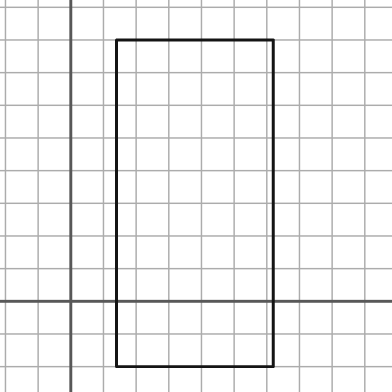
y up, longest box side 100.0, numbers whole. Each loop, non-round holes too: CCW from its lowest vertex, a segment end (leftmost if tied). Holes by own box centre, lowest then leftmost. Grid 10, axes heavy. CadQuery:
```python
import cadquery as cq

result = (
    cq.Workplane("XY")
    .moveTo(14.0, -20.0)
    .lineTo(62.0, -20.0)
    .lineTo(62.0, 80.0)
    .lineTo(14.0, 80.0)
    .close()
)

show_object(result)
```